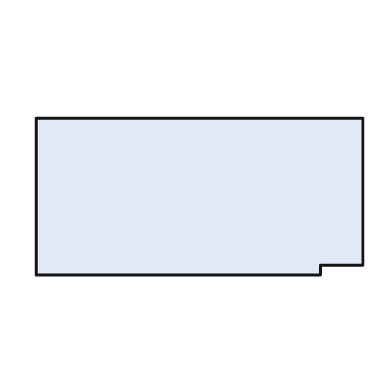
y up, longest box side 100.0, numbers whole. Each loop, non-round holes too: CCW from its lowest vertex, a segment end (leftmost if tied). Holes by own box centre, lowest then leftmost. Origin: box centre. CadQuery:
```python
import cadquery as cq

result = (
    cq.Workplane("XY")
    .moveTo(-50.0, -24.0)
    .lineTo(37.0, -24.0)
    .lineTo(37.0, -21.0)
    .lineTo(50.0, -21.0)
    .lineTo(50.0, 24.0)
    .lineTo(-50.0, 24.0)
    .close()
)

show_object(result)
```